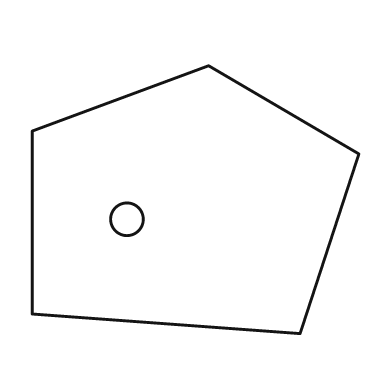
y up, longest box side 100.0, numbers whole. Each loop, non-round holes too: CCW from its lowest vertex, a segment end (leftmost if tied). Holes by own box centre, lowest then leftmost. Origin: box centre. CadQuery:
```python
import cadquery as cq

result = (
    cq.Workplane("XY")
    .moveTo(32.0, -41.0)
    .lineTo(50.0, 14.0)
    .lineTo(4.0, 41.0)
    .lineTo(-50.0, 21.0)
    .lineTo(-50.0, -35.0)
    .close()
    .moveTo(-21.0, -6.0)
    .circle(5.0)
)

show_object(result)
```